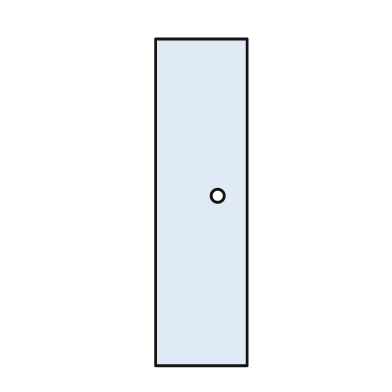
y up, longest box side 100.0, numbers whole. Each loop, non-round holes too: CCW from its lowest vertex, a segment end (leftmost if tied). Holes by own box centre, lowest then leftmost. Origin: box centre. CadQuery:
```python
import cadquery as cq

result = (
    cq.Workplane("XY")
    .moveTo(-14.0, -50.0)
    .lineTo(14.0, -50.0)
    .lineTo(14.0, 50.0)
    .lineTo(-14.0, 50.0)
    .close()
    .moveTo(5.0, 2.0)
    .circle(2.0)
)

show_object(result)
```